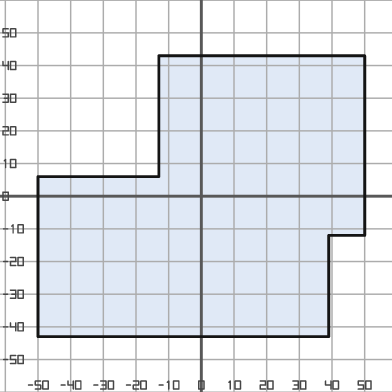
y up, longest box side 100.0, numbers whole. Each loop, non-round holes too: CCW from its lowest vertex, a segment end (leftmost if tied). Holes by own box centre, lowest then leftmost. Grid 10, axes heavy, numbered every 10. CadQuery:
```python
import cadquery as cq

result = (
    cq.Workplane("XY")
    .moveTo(-50.0, -43.0)
    .lineTo(39.0, -43.0)
    .lineTo(39.0, -12.0)
    .lineTo(50.0, -12.0)
    .lineTo(50.0, 43.0)
    .lineTo(-13.0, 43.0)
    .lineTo(-13.0, 6.0)
    .lineTo(-50.0, 6.0)
    .close()
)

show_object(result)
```